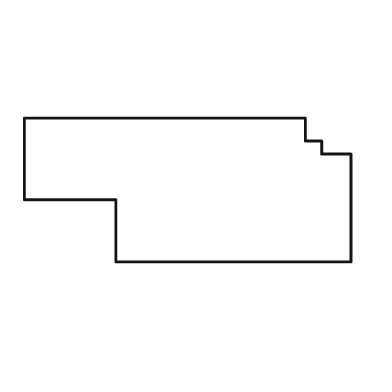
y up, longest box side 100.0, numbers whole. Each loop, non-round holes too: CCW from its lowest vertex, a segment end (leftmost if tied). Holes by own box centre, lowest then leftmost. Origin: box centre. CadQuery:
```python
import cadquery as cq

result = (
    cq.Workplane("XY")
    .moveTo(-22.0, -22.0)
    .lineTo(50.0, -22.0)
    .lineTo(50.0, 11.0)
    .lineTo(41.0, 11.0)
    .lineTo(41.0, 15.0)
    .lineTo(36.0, 15.0)
    .lineTo(36.0, 22.0)
    .lineTo(-50.0, 22.0)
    .lineTo(-50.0, -3.0)
    .lineTo(-22.0, -3.0)
    .close()
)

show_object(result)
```